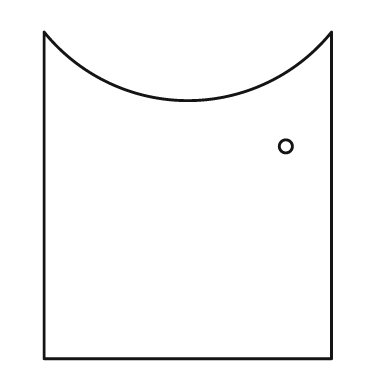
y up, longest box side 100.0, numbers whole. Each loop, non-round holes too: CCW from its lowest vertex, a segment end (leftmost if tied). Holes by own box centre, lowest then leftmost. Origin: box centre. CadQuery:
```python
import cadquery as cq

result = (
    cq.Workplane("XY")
    .moveTo(-44.0, -50.0)
    .lineTo(44.0, -50.0)
    .lineTo(44.0, 50.0)
    .threePointArc((0.0, 29.0), (-44.0, 50.0))
    .close()
    .moveTo(30.0, 15.0)
    .circle(2.0)
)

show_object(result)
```